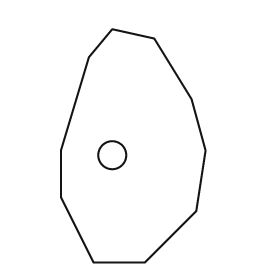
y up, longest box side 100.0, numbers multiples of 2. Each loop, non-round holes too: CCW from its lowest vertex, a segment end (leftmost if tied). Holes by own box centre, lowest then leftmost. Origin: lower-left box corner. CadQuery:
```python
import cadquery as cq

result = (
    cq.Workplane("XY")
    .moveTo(14.0, 0.0)
    .lineTo(36.0, 0.0)
    .lineTo(58.0, 22.0)
    .lineTo(62.0, 48.0)
    .lineTo(56.0, 70.0)
    .lineTo(40.0, 96.0)
    .lineTo(22.0, 100.0)
    .lineTo(12.0, 88.0)
    .lineTo(0.0, 48.0)
    .lineTo(0.0, 28.0)
    .close()
    .moveTo(22.0, 46.0)
    .circle(6.0)
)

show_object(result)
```